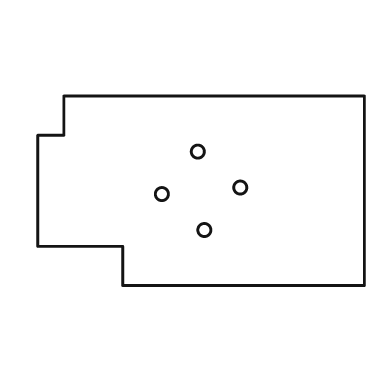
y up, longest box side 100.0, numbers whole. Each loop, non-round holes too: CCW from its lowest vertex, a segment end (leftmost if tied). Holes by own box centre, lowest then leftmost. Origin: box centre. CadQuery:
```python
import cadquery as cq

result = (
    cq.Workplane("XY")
    .moveTo(-24.0, -29.0)
    .lineTo(50.0, -29.0)
    .lineTo(50.0, 29.0)
    .lineTo(-42.0, 29.0)
    .lineTo(-42.0, 17.0)
    .lineTo(-50.0, 17.0)
    .lineTo(-50.0, -17.0)
    .lineTo(-24.0, -17.0)
    .close()
    .moveTo(1.0, -12.0)
    .circle(2.0)
    .moveTo(-12.0, -1.0)
    .circle(2.0)
    .moveTo(12.0, 1.0)
    .circle(2.0)
    .moveTo(-1.0, 12.0)
    .circle(2.0)
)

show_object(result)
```